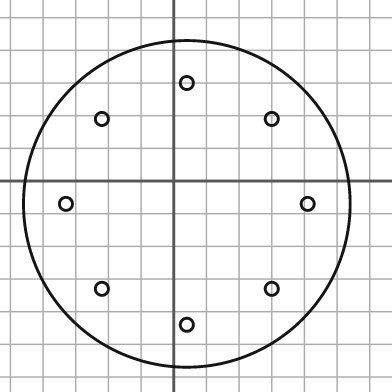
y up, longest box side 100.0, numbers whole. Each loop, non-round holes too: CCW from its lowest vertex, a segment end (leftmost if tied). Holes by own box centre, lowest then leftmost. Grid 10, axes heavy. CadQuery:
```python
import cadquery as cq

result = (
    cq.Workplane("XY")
    .moveTo(4.0, -7.0)
    .circle(50.0)
    .moveTo(4.0, -44.0)
    .circle(2.0)
    .moveTo(-22.0, -33.0)
    .circle(2.0)
    .moveTo(30.0, -33.0)
    .circle(2.0)
    .moveTo(-33.0, -7.0)
    .circle(2.0)
    .moveTo(41.0, -7.0)
    .circle(2.0)
    .moveTo(-22.0, 19.0)
    .circle(2.0)
    .moveTo(30.0, 19.0)
    .circle(2.0)
    .moveTo(4.0, 30.0)
    .circle(2.0)
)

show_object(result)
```